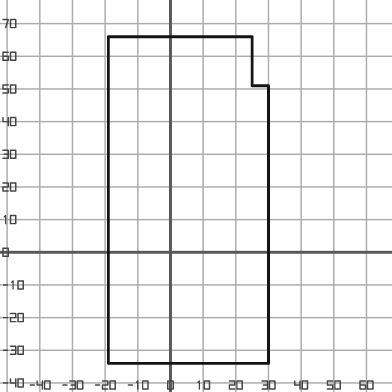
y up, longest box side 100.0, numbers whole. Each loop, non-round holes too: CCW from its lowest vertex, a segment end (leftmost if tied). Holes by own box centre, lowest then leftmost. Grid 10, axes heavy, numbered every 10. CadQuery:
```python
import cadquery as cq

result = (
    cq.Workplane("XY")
    .moveTo(-19.0, -34.0)
    .lineTo(30.0, -34.0)
    .lineTo(30.0, 51.0)
    .lineTo(25.0, 51.0)
    .lineTo(25.0, 66.0)
    .lineTo(-19.0, 66.0)
    .close()
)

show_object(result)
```